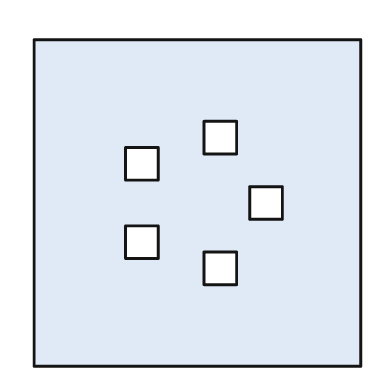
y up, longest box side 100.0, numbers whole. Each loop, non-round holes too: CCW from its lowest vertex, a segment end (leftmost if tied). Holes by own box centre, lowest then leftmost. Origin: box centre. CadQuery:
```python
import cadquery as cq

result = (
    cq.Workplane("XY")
    .moveTo(-50.0, -50.0)
    .lineTo(50.0, -50.0)
    .lineTo(50.0, 50.0)
    .lineTo(-50.0, 50.0)
    .close()
    .moveTo(2.0, -25.0)
    .lineTo(12.0, -25.0)
    .lineTo(12.0, -15.0)
    .lineTo(2.0, -15.0)
    .close()
    .moveTo(-22.0, -17.0)
    .lineTo(-12.0, -17.0)
    .lineTo(-12.0, -7.0)
    .lineTo(-22.0, -7.0)
    .close()
    .moveTo(16.0, -5.0)
    .lineTo(26.0, -5.0)
    .lineTo(26.0, 5.0)
    .lineTo(16.0, 5.0)
    .close()
    .moveTo(-22.0, 7.0)
    .lineTo(-12.0, 7.0)
    .lineTo(-12.0, 17.0)
    .lineTo(-22.0, 17.0)
    .close()
    .moveTo(2.0, 15.0)
    .lineTo(12.0, 15.0)
    .lineTo(12.0, 25.0)
    .lineTo(2.0, 25.0)
    .close()
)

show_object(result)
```